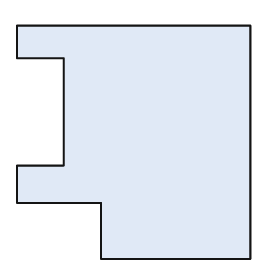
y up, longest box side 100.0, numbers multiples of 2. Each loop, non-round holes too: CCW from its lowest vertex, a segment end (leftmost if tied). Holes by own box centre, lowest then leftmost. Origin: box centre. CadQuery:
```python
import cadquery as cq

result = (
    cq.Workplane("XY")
    .moveTo(-14.0, -50.0)
    .lineTo(50.0, -50.0)
    .lineTo(50.0, 50.0)
    .lineTo(-50.0, 50.0)
    .lineTo(-50.0, 36.0)
    .lineTo(-30.0, 36.0)
    .lineTo(-30.0, -10.0)
    .lineTo(-50.0, -10.0)
    .lineTo(-50.0, -26.0)
    .lineTo(-14.0, -26.0)
    .close()
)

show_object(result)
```